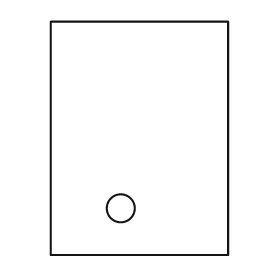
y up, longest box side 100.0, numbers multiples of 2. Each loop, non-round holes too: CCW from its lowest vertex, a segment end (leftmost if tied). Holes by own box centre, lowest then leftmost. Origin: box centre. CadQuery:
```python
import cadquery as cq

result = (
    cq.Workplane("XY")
    .moveTo(-38.0, -50.0)
    .lineTo(38.0, -50.0)
    .lineTo(38.0, 50.0)
    .lineTo(-38.0, 50.0)
    .close()
    .moveTo(-8.0, -30.0)
    .circle(6.0)
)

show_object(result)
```